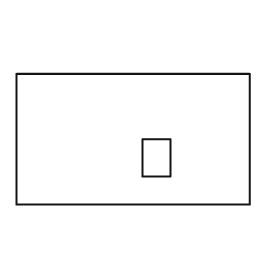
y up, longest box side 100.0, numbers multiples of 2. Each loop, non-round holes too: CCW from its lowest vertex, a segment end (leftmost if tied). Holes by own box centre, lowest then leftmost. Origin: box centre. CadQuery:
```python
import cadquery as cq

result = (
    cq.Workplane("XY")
    .moveTo(-50.0, -28.0)
    .lineTo(50.0, -28.0)
    .lineTo(50.0, 28.0)
    .lineTo(-50.0, 28.0)
    .close()
    .moveTo(4.0, -16.0)
    .lineTo(16.0, -16.0)
    .lineTo(16.0, 0.0)
    .lineTo(4.0, 0.0)
    .close()
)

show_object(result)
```